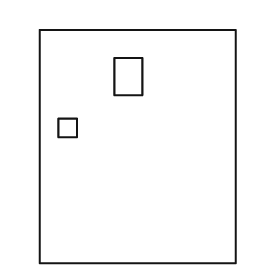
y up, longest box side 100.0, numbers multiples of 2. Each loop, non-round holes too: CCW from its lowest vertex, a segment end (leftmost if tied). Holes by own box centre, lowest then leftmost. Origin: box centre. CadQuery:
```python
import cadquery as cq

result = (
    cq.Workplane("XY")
    .moveTo(-42.0, -50.0)
    .lineTo(42.0, -50.0)
    .lineTo(42.0, 50.0)
    .lineTo(-42.0, 50.0)
    .close()
    .moveTo(-34.0, 4.0)
    .lineTo(-26.0, 4.0)
    .lineTo(-26.0, 12.0)
    .lineTo(-34.0, 12.0)
    .close()
    .moveTo(-10.0, 22.0)
    .lineTo(2.0, 22.0)
    .lineTo(2.0, 38.0)
    .lineTo(-10.0, 38.0)
    .close()
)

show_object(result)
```